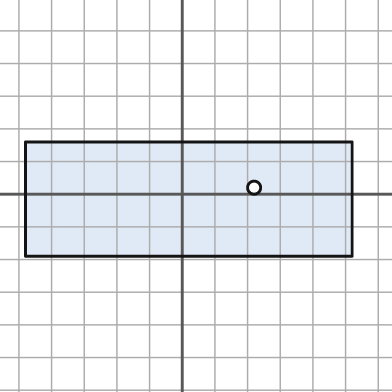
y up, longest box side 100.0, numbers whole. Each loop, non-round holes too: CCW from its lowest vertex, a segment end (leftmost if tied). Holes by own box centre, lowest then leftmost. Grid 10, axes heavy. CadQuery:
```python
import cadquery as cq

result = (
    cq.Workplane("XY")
    .moveTo(-48.0, -19.0)
    .lineTo(52.0, -19.0)
    .lineTo(52.0, 16.0)
    .lineTo(-48.0, 16.0)
    .close()
    .moveTo(22.0, 2.0)
    .circle(2.0)
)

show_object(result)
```